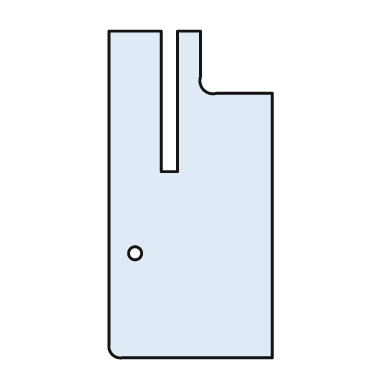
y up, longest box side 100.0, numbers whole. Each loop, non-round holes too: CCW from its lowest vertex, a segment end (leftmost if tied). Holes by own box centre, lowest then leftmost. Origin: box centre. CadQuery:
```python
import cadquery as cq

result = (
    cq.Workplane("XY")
    .moveTo(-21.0, -50.0)
    .lineTo(25.0, -50.0)
    .lineTo(25.0, 31.0)
    .lineTo(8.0, 31.0)
    .threePointArc((4.0, 32.0), (3.0, 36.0))
    .lineTo(3.0, 50.0)
    .lineTo(-4.0, 50.0)
    .lineTo(-4.0, 7.0)
    .lineTo(-9.0, 7.0)
    .lineTo(-9.0, 50.0)
    .lineTo(-25.0, 50.0)
    .lineTo(-25.0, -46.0)
    .threePointArc((-24.0, -49.0), (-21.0, -50.0))
    .close()
    .moveTo(-17.0, -18.0)
    .circle(2.0)
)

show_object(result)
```